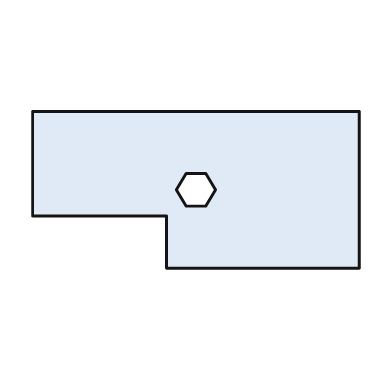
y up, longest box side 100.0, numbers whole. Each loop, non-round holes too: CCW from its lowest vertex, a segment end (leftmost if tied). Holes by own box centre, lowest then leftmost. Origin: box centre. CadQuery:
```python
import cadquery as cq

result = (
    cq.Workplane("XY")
    .moveTo(-9.0, -24.0)
    .lineTo(50.0, -24.0)
    .lineTo(50.0, 24.0)
    .lineTo(-50.0, 24.0)
    .lineTo(-50.0, -8.0)
    .lineTo(-9.0, -8.0)
    .close()
    .moveTo(-3.0, -5.0)
    .lineTo(3.0, -5.0)
    .lineTo(6.0, 0.0)
    .lineTo(3.0, 5.0)
    .lineTo(-3.0, 5.0)
    .lineTo(-6.0, 0.0)
    .close()
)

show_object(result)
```